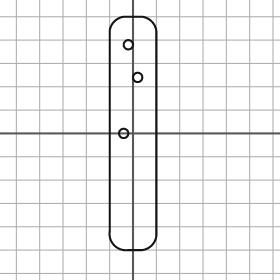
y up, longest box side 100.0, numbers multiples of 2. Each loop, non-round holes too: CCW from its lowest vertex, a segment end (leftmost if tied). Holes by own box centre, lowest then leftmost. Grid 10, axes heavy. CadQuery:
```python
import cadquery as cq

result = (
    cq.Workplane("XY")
    .moveTo(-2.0, -50.0)
    .lineTo(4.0, -50.0)
    .threePointArc((8.0, -48.0), (10.0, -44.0))
    .lineTo(10.0, 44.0)
    .threePointArc((8.0, 48.0), (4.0, 50.0))
    .lineTo(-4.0, 50.0)
    .threePointArc((-8.0, 48.0), (-10.0, 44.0))
    .lineTo(-10.0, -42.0)
    .threePointArc((-8.0, -48.0), (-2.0, -50.0))
    .close()
    .moveTo(-4.0, 0.0)
    .circle(2.0)
    .moveTo(2.0, 24.0)
    .circle(2.0)
    .moveTo(-2.0, 38.0)
    .circle(2.0)
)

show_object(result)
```